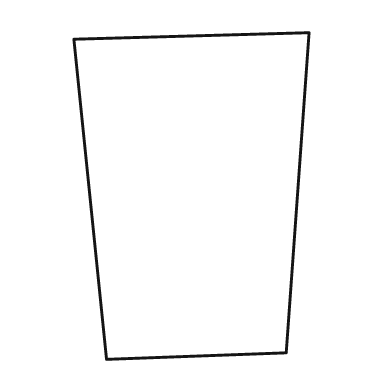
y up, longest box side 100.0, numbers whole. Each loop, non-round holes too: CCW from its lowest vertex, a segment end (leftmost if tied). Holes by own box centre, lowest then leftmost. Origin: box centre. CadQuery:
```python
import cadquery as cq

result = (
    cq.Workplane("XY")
    .moveTo(-26.0, -50.0)
    .lineTo(29.0, -48.0)
    .lineTo(36.0, 50.0)
    .lineTo(-36.0, 48.0)
    .close()
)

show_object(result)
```